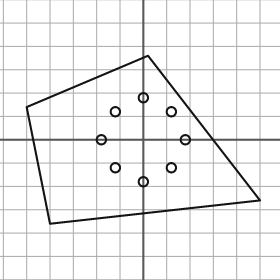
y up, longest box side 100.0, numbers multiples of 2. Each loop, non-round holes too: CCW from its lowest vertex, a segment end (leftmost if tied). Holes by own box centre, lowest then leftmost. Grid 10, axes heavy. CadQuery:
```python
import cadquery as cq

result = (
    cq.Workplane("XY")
    .moveTo(-40.0, -36.0)
    .lineTo(50.0, -26.0)
    .lineTo(2.0, 36.0)
    .lineTo(-50.0, 14.0)
    .close()
    .moveTo(0.0, -18.0)
    .circle(2.0)
    .moveTo(-12.0, -12.0)
    .circle(2.0)
    .moveTo(12.0, -12.0)
    .circle(2.0)
    .moveTo(-18.0, 0.0)
    .circle(2.0)
    .moveTo(18.0, 0.0)
    .circle(2.0)
    .moveTo(-12.0, 12.0)
    .circle(2.0)
    .moveTo(12.0, 12.0)
    .circle(2.0)
    .moveTo(0.0, 18.0)
    .circle(2.0)
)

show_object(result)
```